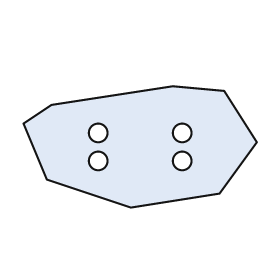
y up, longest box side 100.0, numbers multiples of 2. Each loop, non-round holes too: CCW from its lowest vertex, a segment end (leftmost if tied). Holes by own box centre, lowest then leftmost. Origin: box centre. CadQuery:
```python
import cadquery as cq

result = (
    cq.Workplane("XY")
    .moveTo(-4.0, -26.0)
    .lineTo(34.0, -20.0)
    .lineTo(50.0, 2.0)
    .lineTo(36.0, 24.0)
    .lineTo(14.0, 26.0)
    .lineTo(-38.0, 18.0)
    .lineTo(-50.0, 10.0)
    .lineTo(-40.0, -14.0)
    .close()
    .moveTo(-18.0, -6.0)
    .circle(4.0)
    .moveTo(18.0, -6.0)
    .circle(4.0)
    .moveTo(-18.0, 6.0)
    .circle(4.0)
    .moveTo(18.0, 6.0)
    .circle(4.0)
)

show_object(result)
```